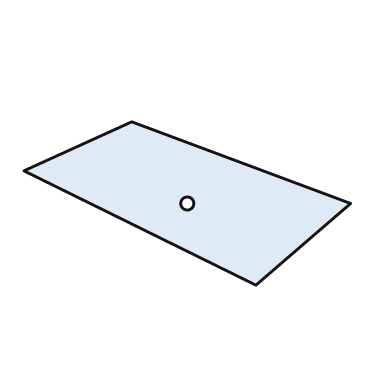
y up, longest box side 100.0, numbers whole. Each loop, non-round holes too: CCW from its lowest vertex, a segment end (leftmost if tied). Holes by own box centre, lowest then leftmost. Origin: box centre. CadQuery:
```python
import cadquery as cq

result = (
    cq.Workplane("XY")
    .moveTo(21.0, -25.0)
    .lineTo(50.0, 0.0)
    .lineTo(-17.0, 25.0)
    .lineTo(-50.0, 10.0)
    .close()
    .moveTo(0.0, 0.0)
    .circle(2.0)
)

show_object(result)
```